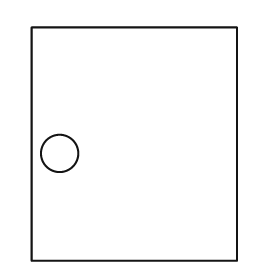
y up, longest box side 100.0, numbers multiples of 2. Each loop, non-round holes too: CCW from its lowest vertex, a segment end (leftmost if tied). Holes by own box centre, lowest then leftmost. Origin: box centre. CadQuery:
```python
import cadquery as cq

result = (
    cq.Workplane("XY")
    .moveTo(-44.0, -50.0)
    .lineTo(44.0, -50.0)
    .lineTo(44.0, 50.0)
    .lineTo(-44.0, 50.0)
    .close()
    .moveTo(-32.0, -4.0)
    .circle(8.0)
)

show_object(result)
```